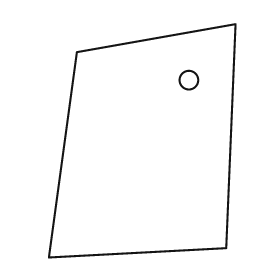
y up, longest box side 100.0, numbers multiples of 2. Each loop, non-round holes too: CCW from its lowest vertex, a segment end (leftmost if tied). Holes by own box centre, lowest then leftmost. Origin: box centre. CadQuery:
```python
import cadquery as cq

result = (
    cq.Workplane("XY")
    .moveTo(-40.0, -50.0)
    .lineTo(36.0, -46.0)
    .lineTo(40.0, 50.0)
    .lineTo(-28.0, 38.0)
    .close()
    .moveTo(20.0, 26.0)
    .circle(4.0)
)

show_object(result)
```